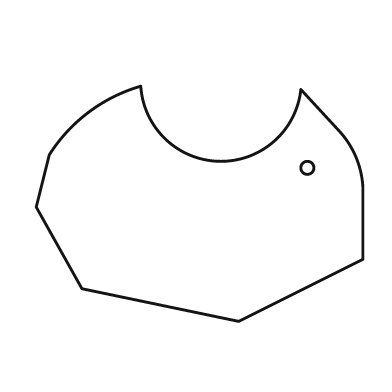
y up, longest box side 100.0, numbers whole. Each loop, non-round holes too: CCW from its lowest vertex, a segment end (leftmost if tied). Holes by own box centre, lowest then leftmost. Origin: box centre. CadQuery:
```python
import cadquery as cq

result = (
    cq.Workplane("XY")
    .moveTo(12.0, -36.0)
    .lineTo(50.0, -17.0)
    .lineTo(50.0, 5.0)
    .threePointArc((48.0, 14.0), (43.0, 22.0))
    .lineTo(31.0, 35.0)
    .threePointArc((6.0, 13.0), (-18.0, 36.0))
    .threePointArc((-34.0, 28.0), (-46.0, 15.0))
    .lineTo(-50.0, -1.0)
    .lineTo(-36.0, -26.0)
    .close()
    .moveTo(33.0, 11.0)
    .circle(2.0)
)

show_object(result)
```